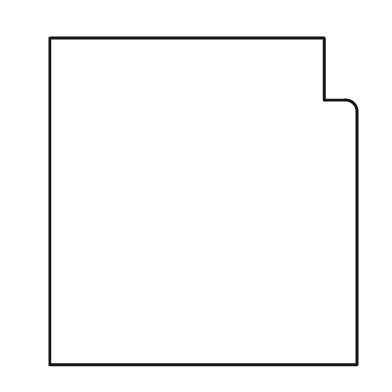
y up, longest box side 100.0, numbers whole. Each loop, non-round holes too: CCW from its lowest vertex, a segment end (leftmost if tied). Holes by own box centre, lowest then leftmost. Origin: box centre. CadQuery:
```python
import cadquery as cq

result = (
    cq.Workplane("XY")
    .moveTo(-47.0, -50.0)
    .lineTo(47.0, -50.0)
    .lineTo(47.0, 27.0)
    .threePointArc((46.0, 30.0), (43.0, 31.0))
    .lineTo(37.0, 31.0)
    .lineTo(37.0, 50.0)
    .lineTo(-47.0, 50.0)
    .close()
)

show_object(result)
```